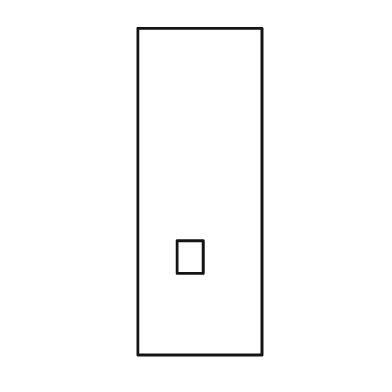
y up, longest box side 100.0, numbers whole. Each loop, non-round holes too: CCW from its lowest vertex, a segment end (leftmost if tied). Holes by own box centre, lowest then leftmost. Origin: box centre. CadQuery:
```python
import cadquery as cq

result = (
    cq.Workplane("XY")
    .moveTo(-19.0, -50.0)
    .lineTo(19.0, -50.0)
    .lineTo(19.0, 50.0)
    .lineTo(-19.0, 50.0)
    .close()
    .moveTo(-7.0, -25.0)
    .lineTo(1.0, -25.0)
    .lineTo(1.0, -15.0)
    .lineTo(-7.0, -15.0)
    .close()
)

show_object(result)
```